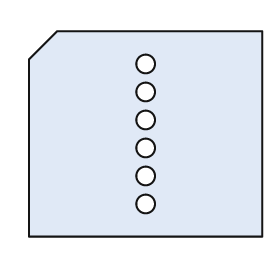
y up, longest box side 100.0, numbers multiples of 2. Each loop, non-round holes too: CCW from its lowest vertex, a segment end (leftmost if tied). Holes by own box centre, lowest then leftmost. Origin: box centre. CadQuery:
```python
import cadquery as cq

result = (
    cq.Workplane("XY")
    .moveTo(-50.0, -44.0)
    .lineTo(50.0, -44.0)
    .lineTo(50.0, 44.0)
    .lineTo(-38.0, 44.0)
    .lineTo(-50.0, 32.0)
    .close()
    .moveTo(0.0, -30.0)
    .circle(4.0)
    .moveTo(0.0, -18.0)
    .circle(4.0)
    .moveTo(0.0, -6.0)
    .circle(4.0)
    .moveTo(0.0, 6.0)
    .circle(4.0)
    .moveTo(0.0, 18.0)
    .circle(4.0)
    .moveTo(0.0, 30.0)
    .circle(4.0)
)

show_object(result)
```